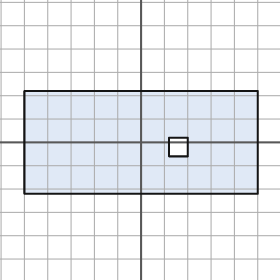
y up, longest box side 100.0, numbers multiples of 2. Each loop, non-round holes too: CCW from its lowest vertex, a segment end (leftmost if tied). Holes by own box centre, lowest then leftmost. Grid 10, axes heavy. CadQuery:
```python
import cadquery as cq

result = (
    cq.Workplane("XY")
    .moveTo(-50.0, -22.0)
    .lineTo(50.0, -22.0)
    .lineTo(50.0, 22.0)
    .lineTo(-50.0, 22.0)
    .close()
    .moveTo(12.0, -6.0)
    .lineTo(20.0, -6.0)
    .lineTo(20.0, 2.0)
    .lineTo(12.0, 2.0)
    .close()
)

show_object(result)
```